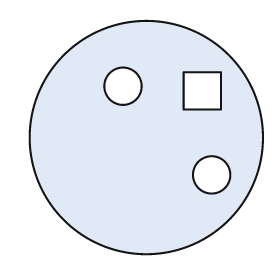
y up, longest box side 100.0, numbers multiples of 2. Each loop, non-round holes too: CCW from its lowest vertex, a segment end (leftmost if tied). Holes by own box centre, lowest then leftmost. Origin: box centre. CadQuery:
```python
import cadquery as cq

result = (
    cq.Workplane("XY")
    .moveTo(0.0, 0.0)
    .circle(50.0)
    .moveTo(28.0, -16.0)
    .circle(8.0)
    .moveTo(16.0, 12.0)
    .lineTo(32.0, 12.0)
    .lineTo(32.0, 28.0)
    .lineTo(16.0, 28.0)
    .close()
    .moveTo(-10.0, 22.0)
    .circle(8.0)
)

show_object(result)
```